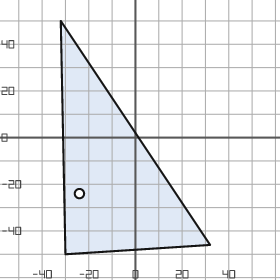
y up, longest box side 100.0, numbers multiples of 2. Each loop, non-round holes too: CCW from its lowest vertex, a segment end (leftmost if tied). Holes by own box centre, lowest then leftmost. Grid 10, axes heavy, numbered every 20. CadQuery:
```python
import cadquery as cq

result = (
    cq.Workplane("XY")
    .moveTo(-30.0, -50.0)
    .lineTo(32.0, -46.0)
    .lineTo(-32.0, 50.0)
    .close()
    .moveTo(-24.0, -24.0)
    .circle(2.0)
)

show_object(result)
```